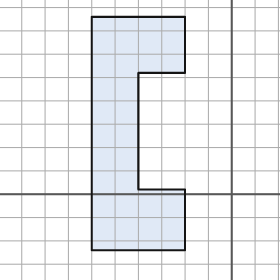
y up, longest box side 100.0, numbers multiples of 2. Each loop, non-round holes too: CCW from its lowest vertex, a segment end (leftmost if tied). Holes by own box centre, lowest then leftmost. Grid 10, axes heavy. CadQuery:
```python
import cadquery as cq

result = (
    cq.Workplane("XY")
    .moveTo(-60.0, -24.0)
    .lineTo(-20.0, -24.0)
    .lineTo(-20.0, 2.0)
    .lineTo(-40.0, 2.0)
    .lineTo(-40.0, 52.0)
    .lineTo(-20.0, 52.0)
    .lineTo(-20.0, 76.0)
    .lineTo(-60.0, 76.0)
    .close()
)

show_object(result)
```